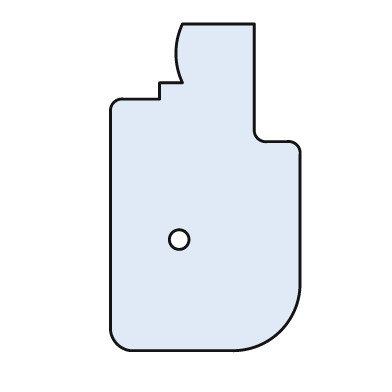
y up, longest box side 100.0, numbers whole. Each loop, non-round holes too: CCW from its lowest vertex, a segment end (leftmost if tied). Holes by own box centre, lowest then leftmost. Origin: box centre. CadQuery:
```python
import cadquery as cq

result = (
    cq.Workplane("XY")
    .moveTo(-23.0, -50.0)
    .lineTo(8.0, -50.0)
    .threePointArc((23.0, -44.0), (29.0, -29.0))
    .lineTo(29.0, 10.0)
    .threePointArc((28.0, 13.0), (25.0, 14.0))
    .lineTo(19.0, 14.0)
    .threePointArc((16.0, 15.0), (15.0, 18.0))
    .lineTo(15.0, 50.0)
    .lineTo(-7.0, 50.0)
    .threePointArc((-9.0, 41.0), (-7.0, 32.0))
    .lineTo(-14.0, 32.0)
    .lineTo(-14.0, 27.0)
    .lineTo(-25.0, 27.0)
    .threePointArc((-28.0, 26.0), (-29.0, 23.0))
    .lineTo(-29.0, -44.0)
    .threePointArc((-27.0, -48.0), (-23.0, -50.0))
    .close()
    .moveTo(-8.0, -16.0)
    .circle(3.0)
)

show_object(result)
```